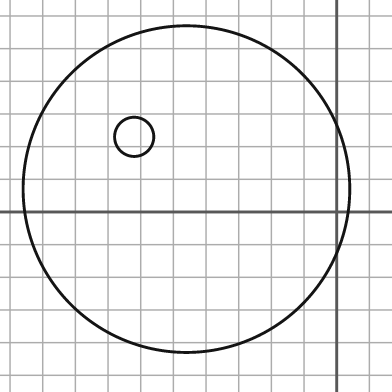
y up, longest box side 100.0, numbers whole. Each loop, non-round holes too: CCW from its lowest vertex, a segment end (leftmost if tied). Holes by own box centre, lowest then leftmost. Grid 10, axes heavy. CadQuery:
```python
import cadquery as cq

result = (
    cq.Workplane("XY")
    .moveTo(-46.0, 7.0)
    .circle(50.0)
    .moveTo(-62.0, 23.0)
    .circle(6.0)
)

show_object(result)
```